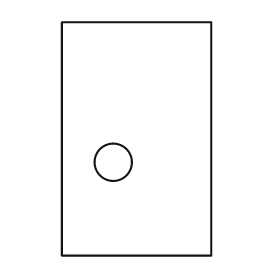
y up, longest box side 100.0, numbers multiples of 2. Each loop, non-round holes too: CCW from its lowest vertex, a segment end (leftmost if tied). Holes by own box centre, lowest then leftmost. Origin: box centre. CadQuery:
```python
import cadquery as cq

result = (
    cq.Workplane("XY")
    .moveTo(-32.0, -50.0)
    .lineTo(32.0, -50.0)
    .lineTo(32.0, 50.0)
    .lineTo(-32.0, 50.0)
    .close()
    .moveTo(-10.0, -10.0)
    .circle(8.0)
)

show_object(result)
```